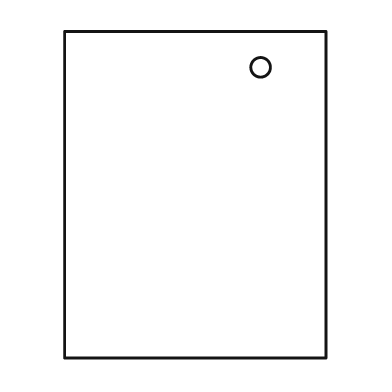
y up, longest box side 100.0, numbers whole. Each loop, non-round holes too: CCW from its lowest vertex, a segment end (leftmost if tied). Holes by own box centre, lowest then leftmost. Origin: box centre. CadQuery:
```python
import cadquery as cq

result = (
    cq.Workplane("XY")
    .moveTo(-40.0, -50.0)
    .lineTo(40.0, -50.0)
    .lineTo(40.0, 50.0)
    .lineTo(-40.0, 50.0)
    .close()
    .moveTo(20.0, 39.0)
    .circle(3.0)
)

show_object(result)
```